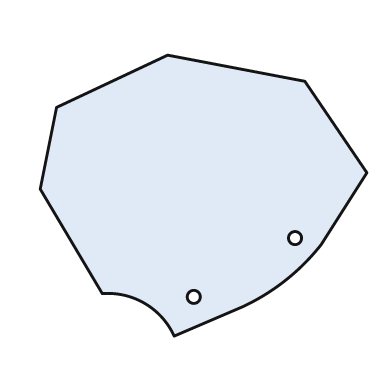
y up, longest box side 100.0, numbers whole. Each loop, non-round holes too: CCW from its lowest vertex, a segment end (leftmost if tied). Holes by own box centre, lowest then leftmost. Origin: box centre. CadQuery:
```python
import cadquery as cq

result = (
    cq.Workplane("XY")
    .moveTo(-9.0, -43.0)
    .lineTo(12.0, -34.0)
    .threePointArc((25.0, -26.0), (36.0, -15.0))
    .lineTo(50.0, 7.0)
    .lineTo(31.0, 35.0)
    .lineTo(-11.0, 43.0)
    .lineTo(-45.0, 27.0)
    .lineTo(-50.0, 2.0)
    .lineTo(-31.0, -30.0)
    .threePointArc((-18.0, -33.0), (-9.0, -43.0))
    .close()
    .moveTo(-3.0, -31.0)
    .circle(2.0)
    .moveTo(28.0, -13.0)
    .circle(2.0)
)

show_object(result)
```